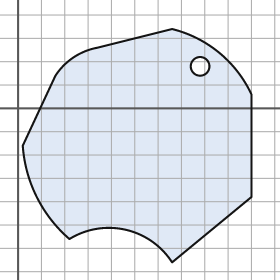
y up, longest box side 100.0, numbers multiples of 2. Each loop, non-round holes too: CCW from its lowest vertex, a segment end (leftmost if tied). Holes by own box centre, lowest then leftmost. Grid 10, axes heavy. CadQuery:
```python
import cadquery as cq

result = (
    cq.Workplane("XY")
    .moveTo(66.0, -66.0)
    .lineTo(100.0, -38.0)
    .lineTo(100.0, 6.0)
    .threePointArc((86.0, 24.0), (66.0, 34.0))
    .lineTo(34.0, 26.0)
    .threePointArc((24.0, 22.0), (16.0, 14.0))
    .lineTo(2.0, -16.0)
    .threePointArc((8.0, -38.0), (22.0, -56.0))
    .threePointArc((46.0, -52.0), (66.0, -66.0))
    .close()
    .moveTo(78.0, 18.0)
    .circle(4.0)
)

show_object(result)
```